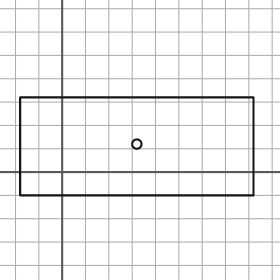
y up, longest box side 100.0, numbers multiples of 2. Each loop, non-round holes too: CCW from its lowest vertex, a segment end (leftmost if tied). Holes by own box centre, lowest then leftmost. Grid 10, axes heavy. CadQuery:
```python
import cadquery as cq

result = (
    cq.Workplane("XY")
    .moveTo(-18.0, -10.0)
    .lineTo(82.0, -10.0)
    .lineTo(82.0, 32.0)
    .lineTo(-18.0, 32.0)
    .close()
    .moveTo(32.0, 12.0)
    .circle(2.0)
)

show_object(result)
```